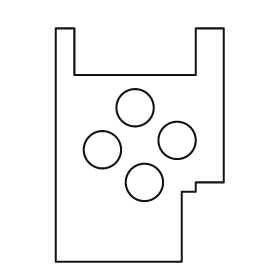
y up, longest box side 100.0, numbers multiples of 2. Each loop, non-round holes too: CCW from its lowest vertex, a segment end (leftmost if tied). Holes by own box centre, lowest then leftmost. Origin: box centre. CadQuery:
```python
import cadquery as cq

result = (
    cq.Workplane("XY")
    .moveTo(-36.0, -50.0)
    .lineTo(18.0, -50.0)
    .lineTo(18.0, -20.0)
    .lineTo(24.0, -20.0)
    .lineTo(24.0, -16.0)
    .lineTo(36.0, -16.0)
    .lineTo(36.0, 50.0)
    .lineTo(24.0, 50.0)
    .lineTo(24.0, 30.0)
    .lineTo(-28.0, 30.0)
    .lineTo(-28.0, 50.0)
    .lineTo(-36.0, 50.0)
    .close()
    .moveTo(2.0, -16.0)
    .circle(8.0)
    .moveTo(-16.0, -2.0)
    .circle(8.0)
    .moveTo(16.0, 2.0)
    .circle(8.0)
    .moveTo(-2.0, 16.0)
    .circle(8.0)
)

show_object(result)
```